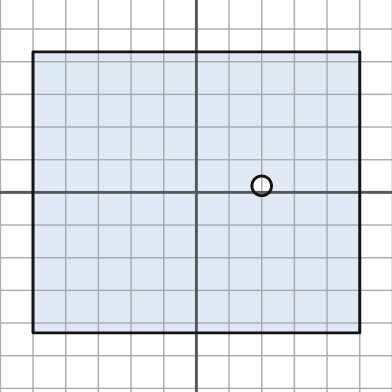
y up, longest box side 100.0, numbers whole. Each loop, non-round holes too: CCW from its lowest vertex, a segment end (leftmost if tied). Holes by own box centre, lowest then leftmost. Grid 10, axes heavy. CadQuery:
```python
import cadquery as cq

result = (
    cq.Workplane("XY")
    .moveTo(-50.0, -43.0)
    .lineTo(50.0, -43.0)
    .lineTo(50.0, 43.0)
    .lineTo(-50.0, 43.0)
    .close()
    .moveTo(20.0, 2.0)
    .circle(3.0)
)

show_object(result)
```